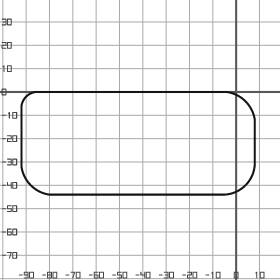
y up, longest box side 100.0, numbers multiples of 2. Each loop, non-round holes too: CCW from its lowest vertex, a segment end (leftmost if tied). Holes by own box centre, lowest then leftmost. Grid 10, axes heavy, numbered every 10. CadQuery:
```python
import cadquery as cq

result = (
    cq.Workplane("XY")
    .moveTo(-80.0, -44.0)
    .lineTo(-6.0, -44.0)
    .threePointArc((4.0, -40.0), (8.0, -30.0))
    .lineTo(8.0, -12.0)
    .threePointArc((4.0, -4.0), (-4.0, 0.0))
    .lineTo(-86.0, 0.0)
    .threePointArc((-90.0, -2.0), (-92.0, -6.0))
    .lineTo(-92.0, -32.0)
    .threePointArc((-88.0, -40.0), (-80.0, -44.0))
    .close()
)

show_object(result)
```